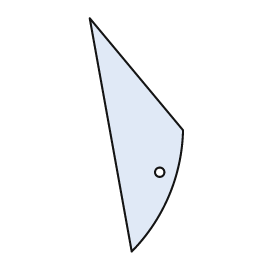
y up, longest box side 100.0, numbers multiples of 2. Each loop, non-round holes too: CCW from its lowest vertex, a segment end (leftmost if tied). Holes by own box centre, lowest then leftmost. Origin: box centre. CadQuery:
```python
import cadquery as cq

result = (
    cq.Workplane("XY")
    .moveTo(-2.0, -50.0)
    .threePointArc((14.0, -26.0), (20.0, 2.0))
    .lineTo(-20.0, 50.0)
    .close()
    .moveTo(10.0, -16.0)
    .circle(2.0)
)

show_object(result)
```